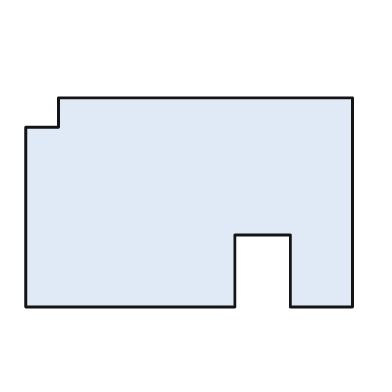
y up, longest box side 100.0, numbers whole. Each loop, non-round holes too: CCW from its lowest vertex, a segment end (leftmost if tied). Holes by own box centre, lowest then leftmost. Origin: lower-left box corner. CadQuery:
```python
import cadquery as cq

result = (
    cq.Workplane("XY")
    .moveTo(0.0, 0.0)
    .lineTo(64.0, 0.0)
    .lineTo(64.0, 22.0)
    .lineTo(81.0, 22.0)
    .lineTo(81.0, 0.0)
    .lineTo(100.0, 0.0)
    .lineTo(100.0, 64.0)
    .lineTo(10.0, 64.0)
    .lineTo(10.0, 55.0)
    .lineTo(0.0, 55.0)
    .close()
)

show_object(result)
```